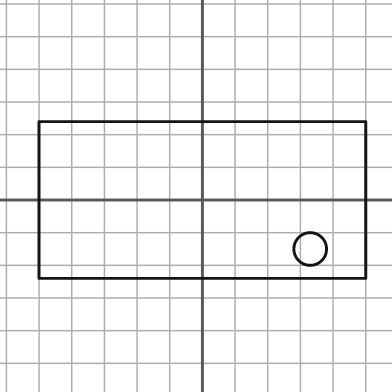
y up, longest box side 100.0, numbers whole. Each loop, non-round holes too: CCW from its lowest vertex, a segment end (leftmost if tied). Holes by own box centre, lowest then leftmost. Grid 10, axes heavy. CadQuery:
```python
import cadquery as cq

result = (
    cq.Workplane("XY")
    .moveTo(-50.0, -24.0)
    .lineTo(50.0, -24.0)
    .lineTo(50.0, 24.0)
    .lineTo(-50.0, 24.0)
    .close()
    .moveTo(33.0, -15.0)
    .circle(5.0)
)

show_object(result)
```